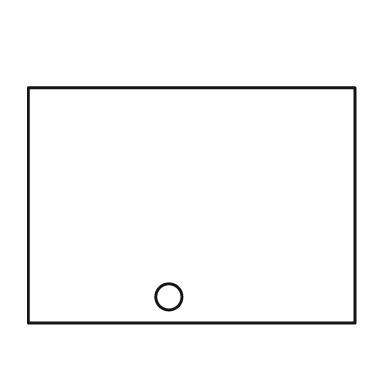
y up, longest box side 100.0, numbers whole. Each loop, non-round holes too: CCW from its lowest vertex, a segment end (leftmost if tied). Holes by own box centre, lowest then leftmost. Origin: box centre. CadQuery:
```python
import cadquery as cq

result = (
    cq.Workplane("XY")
    .moveTo(-50.0, -36.0)
    .lineTo(50.0, -36.0)
    .lineTo(50.0, 36.0)
    .lineTo(-50.0, 36.0)
    .close()
    .moveTo(-7.0, -28.0)
    .circle(4.0)
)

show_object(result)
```